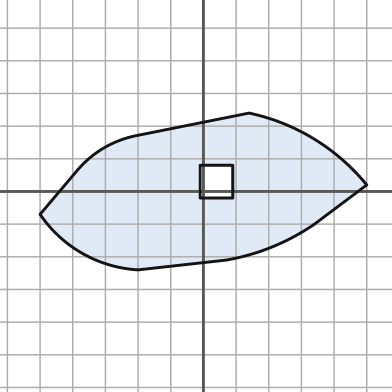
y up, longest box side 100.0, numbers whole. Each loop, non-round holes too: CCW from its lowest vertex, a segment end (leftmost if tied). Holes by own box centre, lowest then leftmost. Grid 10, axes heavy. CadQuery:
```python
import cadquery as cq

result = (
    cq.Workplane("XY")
    .moveTo(-20.0, -24.0)
    .lineTo(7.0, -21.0)
    .threePointArc((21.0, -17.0), (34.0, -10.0))
    .lineTo(50.0, 2.0)
    .threePointArc((34.0, 16.0), (14.0, 24.0))
    .lineTo(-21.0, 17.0)
    .threePointArc((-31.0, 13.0), (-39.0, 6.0))
    .lineTo(-50.0, -7.0)
    .threePointArc((-37.0, -19.0), (-20.0, -24.0))
    .close()
    .moveTo(-1.0, -2.0)
    .lineTo(9.0, -2.0)
    .lineTo(9.0, 8.0)
    .lineTo(-1.0, 8.0)
    .close()
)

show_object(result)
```